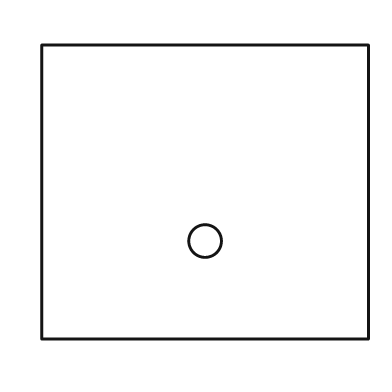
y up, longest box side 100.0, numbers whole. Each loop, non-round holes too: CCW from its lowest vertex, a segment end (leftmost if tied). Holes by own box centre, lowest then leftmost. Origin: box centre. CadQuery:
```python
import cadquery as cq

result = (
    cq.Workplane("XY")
    .moveTo(-50.0, -45.0)
    .lineTo(50.0, -45.0)
    .lineTo(50.0, 45.0)
    .lineTo(-50.0, 45.0)
    .close()
    .moveTo(0.0, -15.0)
    .circle(5.0)
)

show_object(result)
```